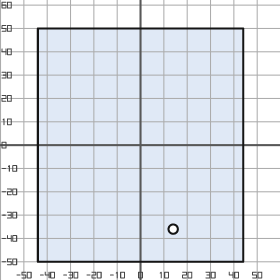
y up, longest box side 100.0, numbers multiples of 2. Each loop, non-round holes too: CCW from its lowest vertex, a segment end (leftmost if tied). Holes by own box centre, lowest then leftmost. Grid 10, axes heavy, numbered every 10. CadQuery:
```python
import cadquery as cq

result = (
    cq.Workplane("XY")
    .moveTo(-44.0, -50.0)
    .lineTo(44.0, -50.0)
    .lineTo(44.0, 50.0)
    .lineTo(-44.0, 50.0)
    .close()
    .moveTo(14.0, -36.0)
    .circle(2.0)
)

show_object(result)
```